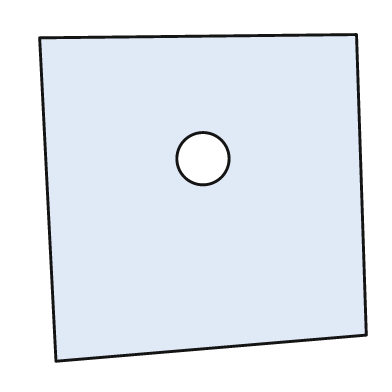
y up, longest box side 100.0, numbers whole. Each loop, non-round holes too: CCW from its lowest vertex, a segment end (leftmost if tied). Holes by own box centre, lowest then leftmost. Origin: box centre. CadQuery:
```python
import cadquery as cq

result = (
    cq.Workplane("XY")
    .moveTo(-45.0, -50.0)
    .lineTo(50.0, -42.0)
    .lineTo(47.0, 50.0)
    .lineTo(-50.0, 49.0)
    .close()
    .moveTo(0.0, 12.0)
    .circle(8.0)
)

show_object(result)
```